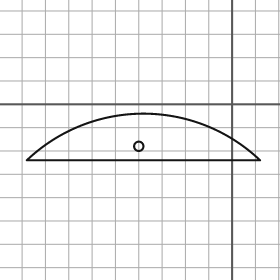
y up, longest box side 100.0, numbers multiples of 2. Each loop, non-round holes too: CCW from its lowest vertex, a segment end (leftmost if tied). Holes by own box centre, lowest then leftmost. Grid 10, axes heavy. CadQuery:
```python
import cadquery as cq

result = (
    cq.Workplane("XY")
    .moveTo(-88.0, -24.0)
    .lineTo(12.0, -24.0)
    .threePointArc((-38.0, -4.0), (-88.0, -24.0))
    .close()
    .moveTo(-40.0, -18.0)
    .circle(2.0)
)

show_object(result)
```